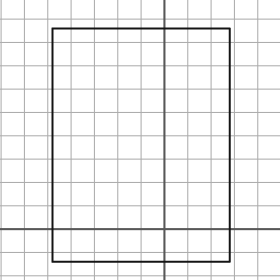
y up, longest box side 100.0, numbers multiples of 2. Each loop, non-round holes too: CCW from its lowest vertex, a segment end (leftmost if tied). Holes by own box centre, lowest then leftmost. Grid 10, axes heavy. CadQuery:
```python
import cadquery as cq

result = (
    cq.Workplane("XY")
    .moveTo(-48.0, -14.0)
    .lineTo(28.0, -14.0)
    .lineTo(28.0, 86.0)
    .lineTo(-48.0, 86.0)
    .close()
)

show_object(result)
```